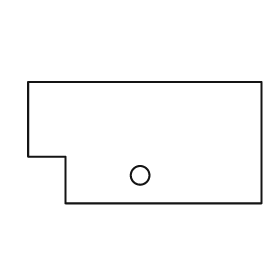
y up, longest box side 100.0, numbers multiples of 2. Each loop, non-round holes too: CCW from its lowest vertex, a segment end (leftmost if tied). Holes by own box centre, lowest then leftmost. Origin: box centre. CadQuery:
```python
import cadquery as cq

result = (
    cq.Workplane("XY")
    .moveTo(-34.0, -26.0)
    .lineTo(50.0, -26.0)
    .lineTo(50.0, 26.0)
    .lineTo(-50.0, 26.0)
    .lineTo(-50.0, -6.0)
    .lineTo(-34.0, -6.0)
    .close()
    .moveTo(-2.0, -14.0)
    .circle(4.0)
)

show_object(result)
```